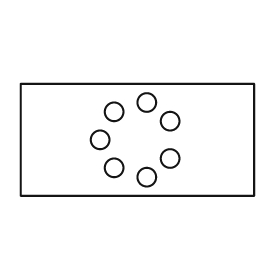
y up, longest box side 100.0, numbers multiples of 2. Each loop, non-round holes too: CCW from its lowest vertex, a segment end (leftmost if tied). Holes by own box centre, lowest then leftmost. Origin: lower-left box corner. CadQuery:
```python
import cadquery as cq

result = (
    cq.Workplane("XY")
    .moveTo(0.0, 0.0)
    .lineTo(100.0, 0.0)
    .lineTo(100.0, 48.0)
    .lineTo(0.0, 48.0)
    .close()
    .moveTo(54.0, 8.0)
    .circle(4.0)
    .moveTo(40.0, 12.0)
    .circle(4.0)
    .moveTo(64.0, 16.0)
    .circle(4.0)
    .moveTo(34.0, 24.0)
    .circle(4.0)
    .moveTo(64.0, 32.0)
    .circle(4.0)
    .moveTo(40.0, 36.0)
    .circle(4.0)
    .moveTo(54.0, 40.0)
    .circle(4.0)
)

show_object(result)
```